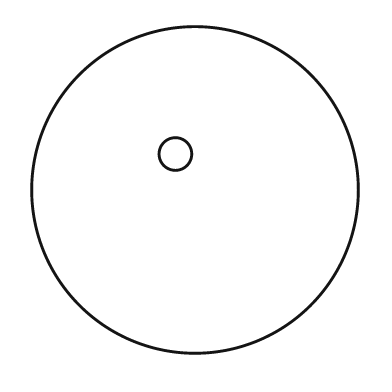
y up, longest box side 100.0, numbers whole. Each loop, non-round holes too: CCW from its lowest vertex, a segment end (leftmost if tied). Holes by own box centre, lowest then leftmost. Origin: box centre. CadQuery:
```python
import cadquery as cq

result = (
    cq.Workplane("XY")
    .moveTo(0.0, 0.0)
    .circle(50.0)
    .moveTo(-6.0, 11.0)
    .circle(5.0)
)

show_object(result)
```